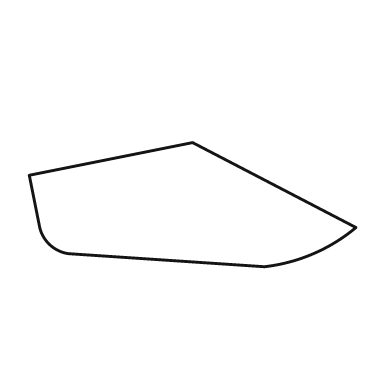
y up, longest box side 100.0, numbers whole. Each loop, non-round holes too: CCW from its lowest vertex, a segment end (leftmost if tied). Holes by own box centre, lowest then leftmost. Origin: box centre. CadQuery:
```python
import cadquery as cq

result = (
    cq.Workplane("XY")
    .moveTo(22.0, -19.0)
    .threePointArc((37.0, -15.0), (50.0, -7.0))
    .lineTo(0.0, 19.0)
    .lineTo(-50.0, 9.0)
    .lineTo(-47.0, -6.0)
    .threePointArc((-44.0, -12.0), (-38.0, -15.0))
    .close()
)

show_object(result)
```